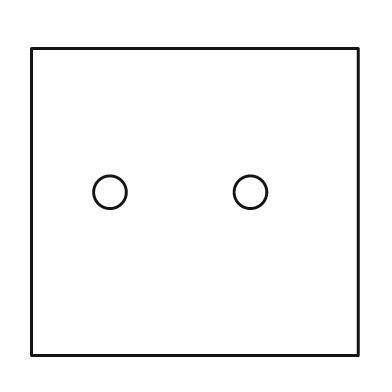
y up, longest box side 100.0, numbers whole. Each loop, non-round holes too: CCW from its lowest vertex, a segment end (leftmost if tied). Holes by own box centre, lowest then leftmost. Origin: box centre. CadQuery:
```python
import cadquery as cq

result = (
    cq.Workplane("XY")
    .moveTo(-50.0, -47.0)
    .lineTo(50.0, -47.0)
    .lineTo(50.0, 47.0)
    .lineTo(-50.0, 47.0)
    .close()
    .moveTo(-26.0, 3.0)
    .circle(5.0)
    .moveTo(17.0, 3.0)
    .circle(5.0)
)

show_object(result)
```